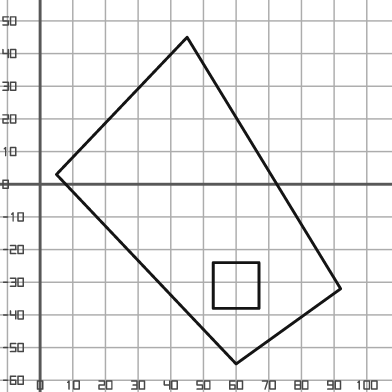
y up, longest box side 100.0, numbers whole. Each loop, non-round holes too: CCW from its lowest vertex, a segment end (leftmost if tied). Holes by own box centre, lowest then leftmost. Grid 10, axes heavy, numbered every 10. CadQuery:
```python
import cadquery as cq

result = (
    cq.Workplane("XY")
    .moveTo(60.0, -55.0)
    .lineTo(92.0, -32.0)
    .lineTo(45.0, 45.0)
    .lineTo(5.0, 3.0)
    .close()
    .moveTo(53.0, -38.0)
    .lineTo(67.0, -38.0)
    .lineTo(67.0, -24.0)
    .lineTo(53.0, -24.0)
    .close()
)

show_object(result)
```